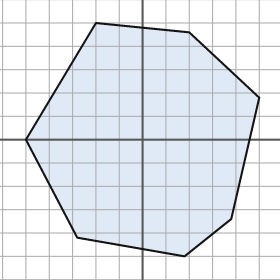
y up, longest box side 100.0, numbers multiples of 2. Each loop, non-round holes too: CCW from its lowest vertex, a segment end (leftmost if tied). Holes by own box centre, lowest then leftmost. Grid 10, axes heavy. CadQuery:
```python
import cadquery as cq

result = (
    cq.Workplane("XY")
    .moveTo(18.0, -50.0)
    .lineTo(38.0, -34.0)
    .lineTo(50.0, 18.0)
    .lineTo(20.0, 46.0)
    .lineTo(-20.0, 50.0)
    .lineTo(-50.0, 0.0)
    .lineTo(-28.0, -42.0)
    .close()
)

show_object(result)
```